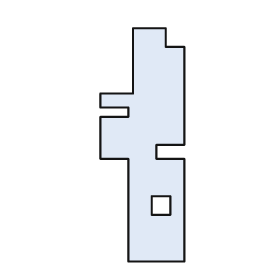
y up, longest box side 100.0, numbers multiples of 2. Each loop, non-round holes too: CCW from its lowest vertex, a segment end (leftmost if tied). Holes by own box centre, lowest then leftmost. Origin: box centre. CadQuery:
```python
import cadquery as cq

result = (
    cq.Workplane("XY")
    .moveTo(-6.0, -50.0)
    .lineTo(18.0, -50.0)
    .lineTo(18.0, -6.0)
    .lineTo(6.0, -6.0)
    .lineTo(6.0, 0.0)
    .lineTo(18.0, 0.0)
    .lineTo(18.0, 42.0)
    .lineTo(10.0, 42.0)
    .lineTo(10.0, 50.0)
    .lineTo(-4.0, 50.0)
    .lineTo(-4.0, 22.0)
    .lineTo(-18.0, 22.0)
    .lineTo(-18.0, 16.0)
    .lineTo(-6.0, 16.0)
    .lineTo(-6.0, 12.0)
    .lineTo(-18.0, 12.0)
    .lineTo(-18.0, -6.0)
    .lineTo(-6.0, -6.0)
    .close()
    .moveTo(4.0, -30.0)
    .lineTo(12.0, -30.0)
    .lineTo(12.0, -22.0)
    .lineTo(4.0, -22.0)
    .close()
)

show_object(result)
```